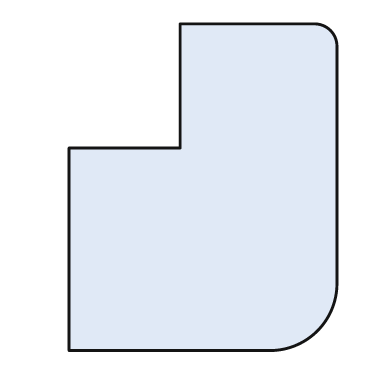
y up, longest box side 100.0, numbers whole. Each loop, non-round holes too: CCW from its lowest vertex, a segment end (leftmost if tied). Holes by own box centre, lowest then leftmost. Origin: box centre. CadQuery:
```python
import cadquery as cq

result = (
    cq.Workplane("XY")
    .moveTo(-41.0, -50.0)
    .lineTo(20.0, -50.0)
    .threePointArc((35.0, -44.0), (41.0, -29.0))
    .lineTo(41.0, 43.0)
    .threePointArc((39.0, 48.0), (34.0, 50.0))
    .lineTo(-7.0, 50.0)
    .lineTo(-7.0, 12.0)
    .lineTo(-41.0, 12.0)
    .close()
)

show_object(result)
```